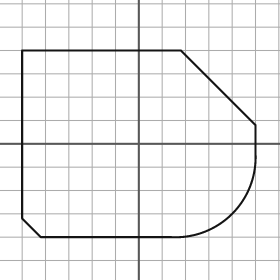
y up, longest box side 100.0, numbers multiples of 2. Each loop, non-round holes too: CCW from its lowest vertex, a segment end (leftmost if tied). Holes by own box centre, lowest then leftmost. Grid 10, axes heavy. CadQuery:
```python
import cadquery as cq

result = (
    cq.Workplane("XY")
    .moveTo(-42.0, -40.0)
    .lineTo(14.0, -40.0)
    .threePointArc((40.0, -30.0), (50.0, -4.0))
    .lineTo(50.0, 8.0)
    .lineTo(18.0, 40.0)
    .lineTo(-50.0, 40.0)
    .lineTo(-50.0, -32.0)
    .close()
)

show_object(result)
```